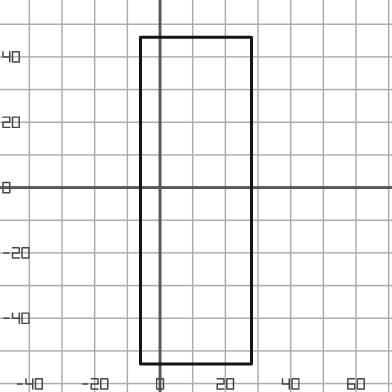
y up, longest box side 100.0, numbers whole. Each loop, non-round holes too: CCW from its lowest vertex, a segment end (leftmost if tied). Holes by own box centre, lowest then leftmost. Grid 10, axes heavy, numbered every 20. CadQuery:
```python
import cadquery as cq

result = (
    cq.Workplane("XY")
    .moveTo(-6.0, -54.0)
    .lineTo(28.0, -54.0)
    .lineTo(28.0, 46.0)
    .lineTo(-6.0, 46.0)
    .close()
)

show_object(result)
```